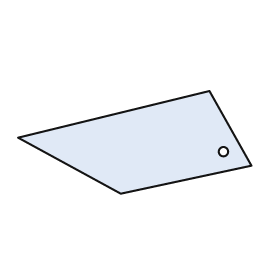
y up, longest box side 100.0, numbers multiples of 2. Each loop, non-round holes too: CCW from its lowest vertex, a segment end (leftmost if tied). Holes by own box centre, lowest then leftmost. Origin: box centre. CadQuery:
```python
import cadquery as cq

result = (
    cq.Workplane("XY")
    .moveTo(-6.0, -22.0)
    .lineTo(50.0, -10.0)
    .lineTo(32.0, 22.0)
    .lineTo(-50.0, 2.0)
    .close()
    .moveTo(38.0, -4.0)
    .circle(2.0)
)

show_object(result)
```